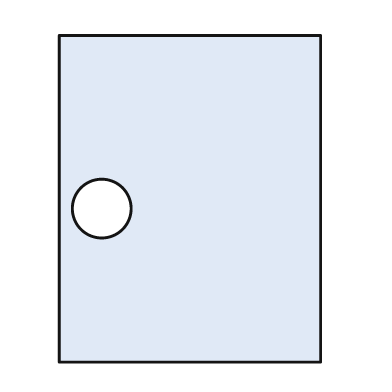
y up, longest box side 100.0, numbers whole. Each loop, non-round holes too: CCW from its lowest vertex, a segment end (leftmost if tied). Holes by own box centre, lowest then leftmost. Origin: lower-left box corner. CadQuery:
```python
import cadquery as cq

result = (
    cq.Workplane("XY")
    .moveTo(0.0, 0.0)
    .lineTo(80.0, 0.0)
    .lineTo(80.0, 100.0)
    .lineTo(0.0, 100.0)
    .close()
    .moveTo(13.0, 47.0)
    .circle(9.0)
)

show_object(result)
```